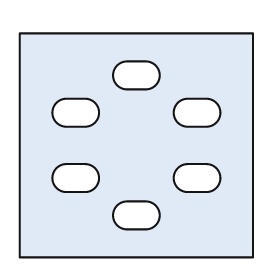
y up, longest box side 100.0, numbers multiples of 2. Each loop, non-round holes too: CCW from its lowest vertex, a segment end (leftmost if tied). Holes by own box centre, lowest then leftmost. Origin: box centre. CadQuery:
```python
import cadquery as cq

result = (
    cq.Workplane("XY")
    .moveTo(-50.0, -48.0)
    .lineTo(50.0, -48.0)
    .lineTo(50.0, 48.0)
    .lineTo(-50.0, 48.0)
    .close()
    .moveTo(-4.0, -36.0)
    .lineTo(4.0, -36.0)
    .threePointArc((10.0, -30.0), (4.0, -24.0))
    .lineTo(-4.0, -24.0)
    .threePointArc((-10.0, -30.0), (-4.0, -36.0))
    .close()
    .moveTo(-30.0, -20.0)
    .lineTo(-22.0, -20.0)
    .threePointArc((-16.0, -14.0), (-22.0, -8.0))
    .lineTo(-30.0, -8.0)
    .threePointArc((-36.0, -14.0), (-30.0, -20.0))
    .close()
    .moveTo(22.0, -20.0)
    .lineTo(30.0, -20.0)
    .threePointArc((36.0, -14.0), (30.0, -8.0))
    .lineTo(22.0, -8.0)
    .threePointArc((16.0, -14.0), (22.0, -20.0))
    .close()
    .moveTo(-30.0, 8.0)
    .lineTo(-22.0, 8.0)
    .threePointArc((-16.0, 14.0), (-22.0, 20.0))
    .lineTo(-30.0, 20.0)
    .threePointArc((-36.0, 14.0), (-30.0, 8.0))
    .close()
    .moveTo(22.0, 8.0)
    .lineTo(30.0, 8.0)
    .threePointArc((36.0, 14.0), (30.0, 20.0))
    .lineTo(22.0, 20.0)
    .threePointArc((16.0, 14.0), (22.0, 8.0))
    .close()
    .moveTo(-4.0, 24.0)
    .lineTo(4.0, 24.0)
    .threePointArc((10.0, 30.0), (4.0, 36.0))
    .lineTo(-4.0, 36.0)
    .threePointArc((-10.0, 30.0), (-4.0, 24.0))
    .close()
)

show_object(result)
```